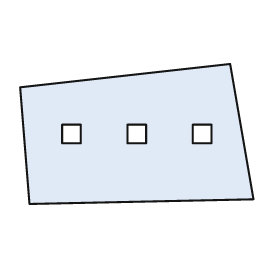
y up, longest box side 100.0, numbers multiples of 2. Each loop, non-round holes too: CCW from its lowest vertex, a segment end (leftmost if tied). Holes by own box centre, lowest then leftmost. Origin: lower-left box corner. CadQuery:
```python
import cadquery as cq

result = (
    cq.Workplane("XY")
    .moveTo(4.0, 0.0)
    .lineTo(100.0, 2.0)
    .lineTo(90.0, 60.0)
    .lineTo(0.0, 50.0)
    .close()
    .moveTo(18.0, 26.0)
    .lineTo(26.0, 26.0)
    .lineTo(26.0, 34.0)
    .lineTo(18.0, 34.0)
    .close()
    .moveTo(46.0, 26.0)
    .lineTo(54.0, 26.0)
    .lineTo(54.0, 34.0)
    .lineTo(46.0, 34.0)
    .close()
    .moveTo(74.0, 26.0)
    .lineTo(82.0, 26.0)
    .lineTo(82.0, 34.0)
    .lineTo(74.0, 34.0)
    .close()
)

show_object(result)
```